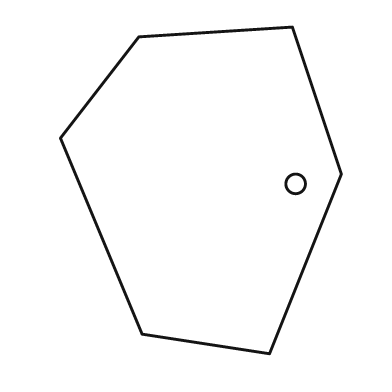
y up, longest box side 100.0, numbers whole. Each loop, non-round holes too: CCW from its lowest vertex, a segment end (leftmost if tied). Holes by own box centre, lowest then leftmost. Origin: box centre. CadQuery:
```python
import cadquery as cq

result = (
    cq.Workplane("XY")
    .moveTo(21.0, -50.0)
    .lineTo(43.0, 5.0)
    .lineTo(28.0, 50.0)
    .lineTo(-19.0, 47.0)
    .lineTo(-43.0, 16.0)
    .lineTo(-18.0, -44.0)
    .close()
    .moveTo(29.0, 2.0)
    .circle(3.0)
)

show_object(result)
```